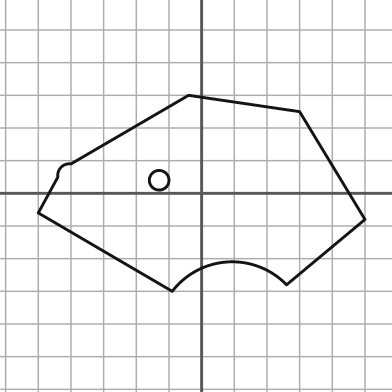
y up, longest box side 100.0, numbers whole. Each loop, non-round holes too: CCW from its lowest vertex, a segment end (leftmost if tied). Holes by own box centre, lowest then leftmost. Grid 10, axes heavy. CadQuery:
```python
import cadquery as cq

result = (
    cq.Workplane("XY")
    .moveTo(-9.0, -30.0)
    .threePointArc((8.0, -21.0), (26.0, -28.0))
    .lineTo(50.0, -8.0)
    .lineTo(30.0, 25.0)
    .lineTo(-4.0, 30.0)
    .lineTo(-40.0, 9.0)
    .threePointArc((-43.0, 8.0), (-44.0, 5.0))
    .lineTo(-50.0, -6.0)
    .close()
    .moveTo(-13.0, 4.0)
    .circle(3.0)
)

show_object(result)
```